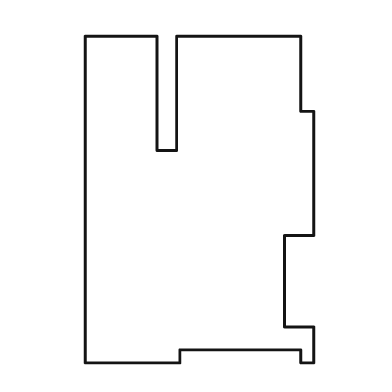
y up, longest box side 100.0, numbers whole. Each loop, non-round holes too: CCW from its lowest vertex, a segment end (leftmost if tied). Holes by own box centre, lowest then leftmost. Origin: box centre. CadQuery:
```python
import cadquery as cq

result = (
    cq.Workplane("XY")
    .moveTo(-35.0, -50.0)
    .lineTo(-6.0, -50.0)
    .lineTo(-6.0, -46.0)
    .lineTo(31.0, -46.0)
    .lineTo(31.0, -50.0)
    .lineTo(35.0, -50.0)
    .lineTo(35.0, -39.0)
    .lineTo(26.0, -39.0)
    .lineTo(26.0, -11.0)
    .lineTo(35.0, -11.0)
    .lineTo(35.0, 27.0)
    .lineTo(31.0, 27.0)
    .lineTo(31.0, 50.0)
    .lineTo(-7.0, 50.0)
    .lineTo(-7.0, 15.0)
    .lineTo(-13.0, 15.0)
    .lineTo(-13.0, 50.0)
    .lineTo(-35.0, 50.0)
    .close()
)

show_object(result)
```